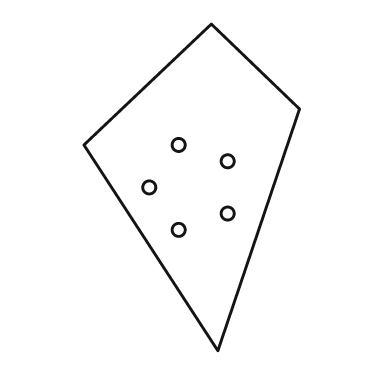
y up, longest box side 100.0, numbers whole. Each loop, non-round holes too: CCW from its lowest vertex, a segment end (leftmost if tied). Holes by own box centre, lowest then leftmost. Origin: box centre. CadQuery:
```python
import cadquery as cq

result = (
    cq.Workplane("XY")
    .moveTo(8.0, -50.0)
    .lineTo(33.0, 24.0)
    .lineTo(6.0, 50.0)
    .lineTo(-33.0, 13.0)
    .close()
    .moveTo(-4.0, -13.0)
    .circle(2.0)
    .moveTo(11.0, -8.0)
    .circle(2.0)
    .moveTo(-13.0, 0.0)
    .circle(2.0)
    .moveTo(11.0, 8.0)
    .circle(2.0)
    .moveTo(-4.0, 13.0)
    .circle(2.0)
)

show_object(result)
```